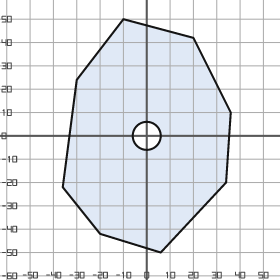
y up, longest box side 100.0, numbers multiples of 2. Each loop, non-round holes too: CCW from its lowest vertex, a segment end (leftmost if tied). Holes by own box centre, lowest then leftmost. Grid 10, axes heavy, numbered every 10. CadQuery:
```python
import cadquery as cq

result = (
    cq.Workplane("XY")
    .moveTo(6.0, -50.0)
    .lineTo(34.0, -20.0)
    .lineTo(36.0, 10.0)
    .lineTo(20.0, 42.0)
    .lineTo(-10.0, 50.0)
    .lineTo(-30.0, 24.0)
    .lineTo(-36.0, -22.0)
    .lineTo(-20.0, -42.0)
    .close()
    .moveTo(0.0, 0.0)
    .circle(6.0)
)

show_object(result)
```